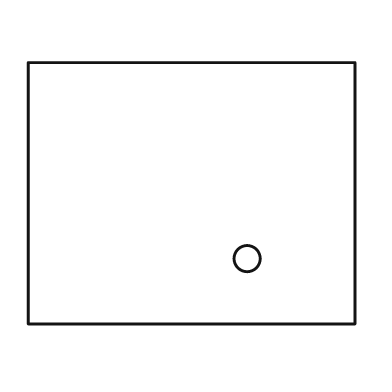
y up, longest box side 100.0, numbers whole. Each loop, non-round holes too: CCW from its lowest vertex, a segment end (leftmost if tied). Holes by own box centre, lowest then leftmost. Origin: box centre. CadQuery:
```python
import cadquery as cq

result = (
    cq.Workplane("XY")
    .moveTo(-50.0, -40.0)
    .lineTo(50.0, -40.0)
    .lineTo(50.0, 40.0)
    .lineTo(-50.0, 40.0)
    .close()
    .moveTo(17.0, -20.0)
    .circle(4.0)
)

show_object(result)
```